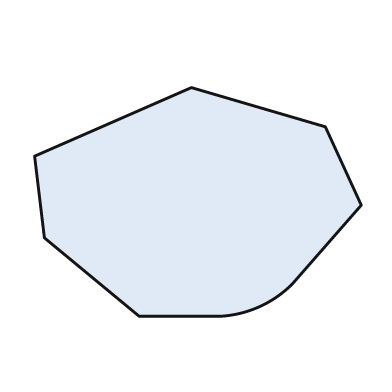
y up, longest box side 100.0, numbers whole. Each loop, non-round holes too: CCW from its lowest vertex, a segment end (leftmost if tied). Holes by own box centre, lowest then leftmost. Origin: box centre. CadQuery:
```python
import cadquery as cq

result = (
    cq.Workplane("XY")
    .moveTo(-18.0, -35.0)
    .lineTo(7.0, -35.0)
    .threePointArc((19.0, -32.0), (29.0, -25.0))
    .lineTo(50.0, -1.0)
    .lineTo(39.0, 23.0)
    .lineTo(-2.0, 35.0)
    .lineTo(-50.0, 14.0)
    .lineTo(-47.0, -11.0)
    .close()
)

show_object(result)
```